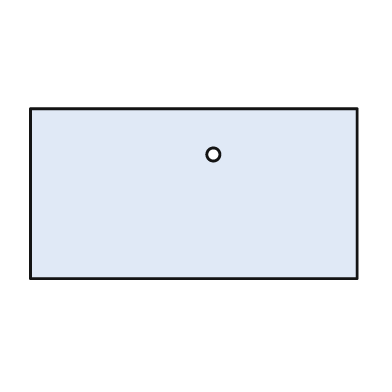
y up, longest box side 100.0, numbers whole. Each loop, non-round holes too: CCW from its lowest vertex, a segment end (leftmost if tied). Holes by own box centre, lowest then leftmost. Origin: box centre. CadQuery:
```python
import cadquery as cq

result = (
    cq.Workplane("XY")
    .moveTo(-50.0, -26.0)
    .lineTo(50.0, -26.0)
    .lineTo(50.0, 26.0)
    .lineTo(-50.0, 26.0)
    .close()
    .moveTo(6.0, 12.0)
    .circle(2.0)
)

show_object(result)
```